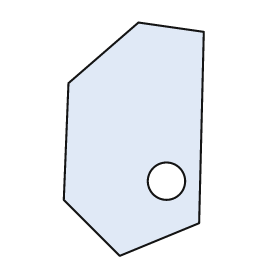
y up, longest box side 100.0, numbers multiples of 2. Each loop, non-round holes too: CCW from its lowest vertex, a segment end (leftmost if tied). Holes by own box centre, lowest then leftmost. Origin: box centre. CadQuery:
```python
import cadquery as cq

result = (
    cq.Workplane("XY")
    .moveTo(-6.0, -50.0)
    .lineTo(28.0, -36.0)
    .lineTo(30.0, 46.0)
    .lineTo(2.0, 50.0)
    .lineTo(-28.0, 24.0)
    .lineTo(-30.0, -26.0)
    .close()
    .moveTo(14.0, -18.0)
    .circle(8.0)
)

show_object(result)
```